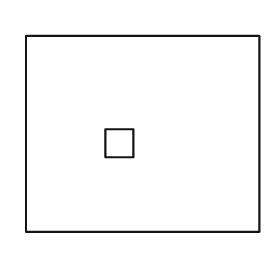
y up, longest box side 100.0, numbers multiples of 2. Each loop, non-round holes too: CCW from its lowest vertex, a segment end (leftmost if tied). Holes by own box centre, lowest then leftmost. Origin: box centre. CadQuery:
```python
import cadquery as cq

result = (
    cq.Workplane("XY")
    .moveTo(-50.0, -42.0)
    .lineTo(50.0, -42.0)
    .lineTo(50.0, 42.0)
    .lineTo(-50.0, 42.0)
    .close()
    .moveTo(-16.0, -10.0)
    .lineTo(-4.0, -10.0)
    .lineTo(-4.0, 2.0)
    .lineTo(-16.0, 2.0)
    .close()
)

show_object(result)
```